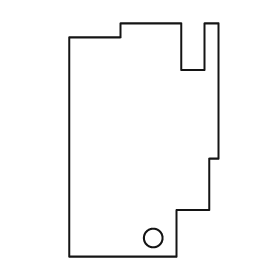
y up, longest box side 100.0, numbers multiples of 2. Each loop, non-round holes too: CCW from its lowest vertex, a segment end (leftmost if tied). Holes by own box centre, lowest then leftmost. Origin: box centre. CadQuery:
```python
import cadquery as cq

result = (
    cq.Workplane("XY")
    .moveTo(-32.0, -50.0)
    .lineTo(14.0, -50.0)
    .lineTo(14.0, -30.0)
    .lineTo(28.0, -30.0)
    .lineTo(28.0, -8.0)
    .lineTo(32.0, -8.0)
    .lineTo(32.0, 50.0)
    .lineTo(26.0, 50.0)
    .lineTo(26.0, 30.0)
    .lineTo(16.0, 30.0)
    .lineTo(16.0, 50.0)
    .lineTo(-10.0, 50.0)
    .lineTo(-10.0, 44.0)
    .lineTo(-32.0, 44.0)
    .close()
    .moveTo(4.0, -42.0)
    .circle(4.0)
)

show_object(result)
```